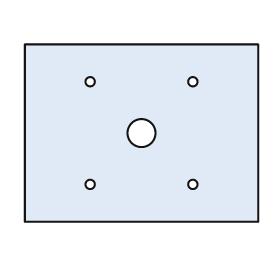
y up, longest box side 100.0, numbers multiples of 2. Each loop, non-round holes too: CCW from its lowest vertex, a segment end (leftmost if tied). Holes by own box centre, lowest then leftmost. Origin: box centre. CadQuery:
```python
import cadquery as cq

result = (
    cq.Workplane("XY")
    .moveTo(-50.0, -38.0)
    .lineTo(50.0, -38.0)
    .lineTo(50.0, 38.0)
    .lineTo(-50.0, 38.0)
    .close()
    .moveTo(-22.0, -22.0)
    .circle(2.0)
    .moveTo(22.0, -22.0)
    .circle(2.0)
    .moveTo(0.0, 0.0)
    .circle(6.0)
    .moveTo(-22.0, 22.0)
    .circle(2.0)
    .moveTo(22.0, 22.0)
    .circle(2.0)
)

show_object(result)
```